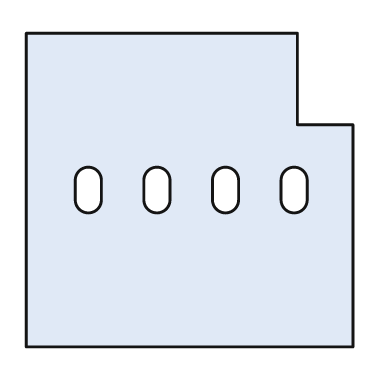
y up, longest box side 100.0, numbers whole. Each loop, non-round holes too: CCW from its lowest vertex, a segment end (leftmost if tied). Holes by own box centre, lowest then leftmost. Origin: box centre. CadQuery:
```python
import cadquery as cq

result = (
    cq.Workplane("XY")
    .moveTo(-50.0, -48.0)
    .lineTo(50.0, -48.0)
    .lineTo(50.0, 20.0)
    .lineTo(33.0, 20.0)
    .lineTo(33.0, 48.0)
    .lineTo(-50.0, 48.0)
    .close()
    .moveTo(-35.0, -3.0)
    .threePointArc((-31.0, -7.0), (-27.0, -3.0))
    .lineTo(-27.0, 3.0)
    .threePointArc((-31.0, 7.0), (-35.0, 3.0))
    .close()
    .moveTo(-14.0, -3.0)
    .threePointArc((-10.0, -7.0), (-6.0, -3.0))
    .lineTo(-6.0, 3.0)
    .threePointArc((-10.0, 7.0), (-14.0, 3.0))
    .close()
    .moveTo(7.0, -3.0)
    .threePointArc((11.0, -7.0), (15.0, -3.0))
    .lineTo(15.0, 3.0)
    .threePointArc((11.0, 7.0), (7.0, 3.0))
    .close()
    .moveTo(28.0, -3.0)
    .threePointArc((32.0, -7.0), (36.0, -3.0))
    .lineTo(36.0, 3.0)
    .threePointArc((32.0, 7.0), (28.0, 3.0))
    .close()
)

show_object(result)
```